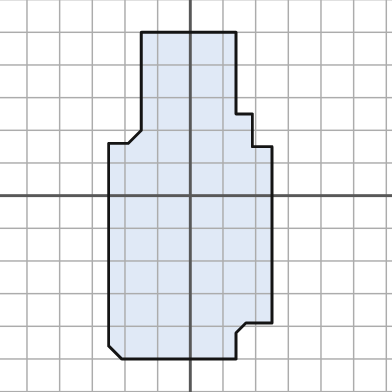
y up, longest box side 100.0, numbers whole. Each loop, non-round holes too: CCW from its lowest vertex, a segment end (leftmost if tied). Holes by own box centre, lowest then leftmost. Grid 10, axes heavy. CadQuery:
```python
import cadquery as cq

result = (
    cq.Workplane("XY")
    .moveTo(-21.0, -50.0)
    .lineTo(14.0, -50.0)
    .lineTo(14.0, -42.0)
    .lineTo(17.0, -39.0)
    .lineTo(25.0, -39.0)
    .lineTo(25.0, 15.0)
    .lineTo(19.0, 15.0)
    .lineTo(19.0, 25.0)
    .lineTo(14.0, 25.0)
    .lineTo(14.0, 50.0)
    .lineTo(-15.0, 50.0)
    .lineTo(-15.0, 20.0)
    .lineTo(-19.0, 16.0)
    .lineTo(-25.0, 16.0)
    .lineTo(-25.0, -46.0)
    .close()
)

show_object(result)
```